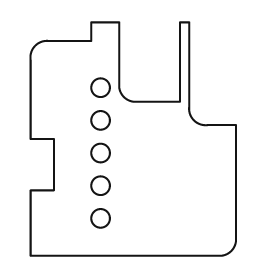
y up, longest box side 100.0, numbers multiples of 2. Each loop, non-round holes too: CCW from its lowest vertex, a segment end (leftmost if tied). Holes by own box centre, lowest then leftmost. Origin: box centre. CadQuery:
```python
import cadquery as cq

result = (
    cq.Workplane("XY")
    .moveTo(-44.0, -50.0)
    .lineTo(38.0, -50.0)
    .threePointArc((42.0, -48.0), (44.0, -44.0))
    .lineTo(44.0, 6.0)
    .lineTo(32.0, 6.0)
    .threePointArc((26.0, 8.0), (24.0, 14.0))
    .lineTo(24.0, 50.0)
    .lineTo(20.0, 50.0)
    .lineTo(20.0, 16.0)
    .lineTo(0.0, 16.0)
    .threePointArc((-4.0, 18.0), (-6.0, 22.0))
    .lineTo(-6.0, 50.0)
    .lineTo(-18.0, 50.0)
    .lineTo(-18.0, 42.0)
    .lineTo(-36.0, 42.0)
    .threePointArc((-42.0, 40.0), (-44.0, 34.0))
    .lineTo(-44.0, 0.0)
    .lineTo(-34.0, 0.0)
    .lineTo(-34.0, -22.0)
    .lineTo(-44.0, -22.0)
    .close()
    .moveTo(-14.0, -34.0)
    .circle(4.0)
    .moveTo(-14.0, -20.0)
    .circle(4.0)
    .moveTo(-14.0, -6.0)
    .circle(4.0)
    .moveTo(-14.0, 8.0)
    .circle(4.0)
    .moveTo(-14.0, 22.0)
    .circle(4.0)
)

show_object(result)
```